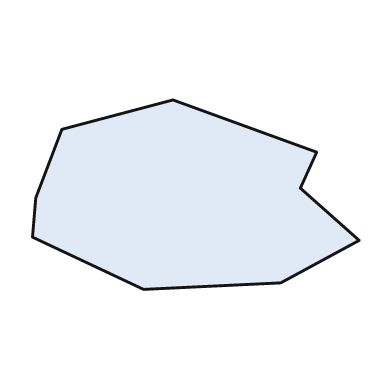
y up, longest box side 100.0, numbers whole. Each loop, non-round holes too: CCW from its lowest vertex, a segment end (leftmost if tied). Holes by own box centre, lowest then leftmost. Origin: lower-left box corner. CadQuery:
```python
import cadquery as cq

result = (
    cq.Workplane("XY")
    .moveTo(34.0, 0.0)
    .lineTo(76.0, 2.0)
    .lineTo(100.0, 15.0)
    .lineTo(82.0, 31.0)
    .lineTo(87.0, 42.0)
    .lineTo(43.0, 58.0)
    .lineTo(9.0, 49.0)
    .lineTo(1.0, 28.0)
    .lineTo(0.0, 16.0)
    .close()
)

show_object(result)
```